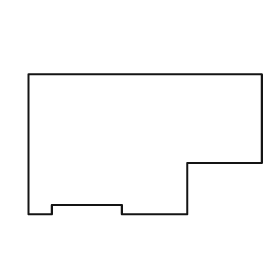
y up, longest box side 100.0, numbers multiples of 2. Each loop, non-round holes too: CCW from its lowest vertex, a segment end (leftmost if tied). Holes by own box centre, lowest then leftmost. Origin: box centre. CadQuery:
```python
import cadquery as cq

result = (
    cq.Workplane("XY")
    .moveTo(-50.0, -30.0)
    .lineTo(-40.0, -30.0)
    .lineTo(-40.0, -26.0)
    .lineTo(-10.0, -26.0)
    .lineTo(-10.0, -30.0)
    .lineTo(18.0, -30.0)
    .lineTo(18.0, -8.0)
    .lineTo(50.0, -8.0)
    .lineTo(50.0, 30.0)
    .lineTo(-50.0, 30.0)
    .close()
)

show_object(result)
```